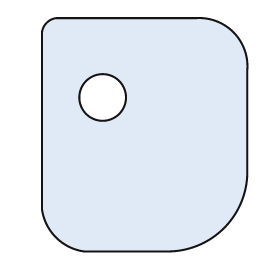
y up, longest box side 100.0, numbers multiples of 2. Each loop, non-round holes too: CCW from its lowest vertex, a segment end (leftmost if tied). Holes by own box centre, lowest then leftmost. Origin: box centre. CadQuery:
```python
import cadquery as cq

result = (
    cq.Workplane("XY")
    .moveTo(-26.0, -50.0)
    .lineTo(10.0, -50.0)
    .threePointArc((34.0, -40.0), (44.0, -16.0))
    .lineTo(44.0, 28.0)
    .threePointArc((38.0, 44.0), (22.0, 50.0))
    .lineTo(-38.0, 50.0)
    .threePointArc((-42.0, 48.0), (-44.0, 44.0))
    .lineTo(-44.0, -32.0)
    .threePointArc((-38.0, -44.0), (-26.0, -50.0))
    .close()
    .moveTo(-18.0, 16.0)
    .circle(10.0)
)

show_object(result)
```